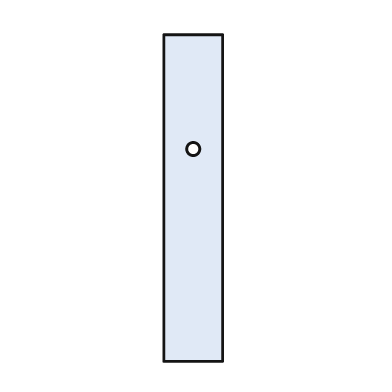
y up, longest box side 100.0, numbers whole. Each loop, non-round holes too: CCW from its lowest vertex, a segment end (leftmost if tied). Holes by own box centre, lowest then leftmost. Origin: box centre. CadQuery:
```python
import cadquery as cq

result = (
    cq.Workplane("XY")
    .moveTo(-9.0, -50.0)
    .lineTo(9.0, -50.0)
    .lineTo(9.0, 50.0)
    .lineTo(-9.0, 50.0)
    .close()
    .moveTo(0.0, 15.0)
    .circle(2.0)
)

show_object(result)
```